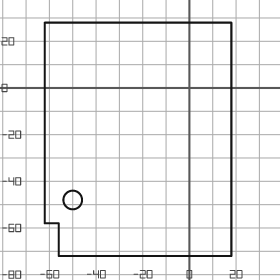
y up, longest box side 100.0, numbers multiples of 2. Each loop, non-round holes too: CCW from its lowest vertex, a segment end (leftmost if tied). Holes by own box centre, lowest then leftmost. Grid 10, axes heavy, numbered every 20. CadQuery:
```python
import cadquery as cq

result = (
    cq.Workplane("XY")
    .moveTo(-56.0, -72.0)
    .lineTo(18.0, -72.0)
    .lineTo(18.0, 28.0)
    .lineTo(-62.0, 28.0)
    .lineTo(-62.0, -58.0)
    .lineTo(-56.0, -58.0)
    .close()
    .moveTo(-50.0, -48.0)
    .circle(4.0)
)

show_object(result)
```